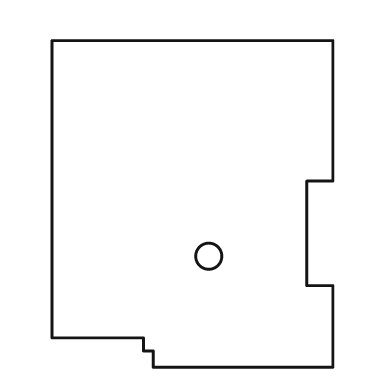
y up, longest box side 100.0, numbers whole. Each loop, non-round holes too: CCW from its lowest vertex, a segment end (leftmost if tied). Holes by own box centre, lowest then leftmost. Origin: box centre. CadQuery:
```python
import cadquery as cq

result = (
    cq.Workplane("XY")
    .moveTo(-12.0, -50.0)
    .lineTo(43.0, -50.0)
    .lineTo(43.0, -25.0)
    .lineTo(35.0, -25.0)
    .lineTo(35.0, 7.0)
    .lineTo(43.0, 7.0)
    .lineTo(43.0, 50.0)
    .lineTo(-43.0, 50.0)
    .lineTo(-43.0, -41.0)
    .lineTo(-15.0, -41.0)
    .lineTo(-15.0, -45.0)
    .lineTo(-12.0, -45.0)
    .close()
    .moveTo(5.0, -16.0)
    .circle(4.0)
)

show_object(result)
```